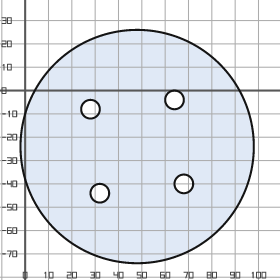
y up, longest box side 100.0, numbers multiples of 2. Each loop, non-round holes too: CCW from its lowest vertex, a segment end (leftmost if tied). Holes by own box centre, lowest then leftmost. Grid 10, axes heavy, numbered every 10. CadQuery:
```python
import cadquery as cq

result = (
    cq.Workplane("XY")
    .moveTo(48.0, -24.0)
    .circle(50.0)
    .moveTo(32.0, -44.0)
    .circle(4.0)
    .moveTo(68.0, -40.0)
    .circle(4.0)
    .moveTo(28.0, -8.0)
    .circle(4.0)
    .moveTo(64.0, -4.0)
    .circle(4.0)
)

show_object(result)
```